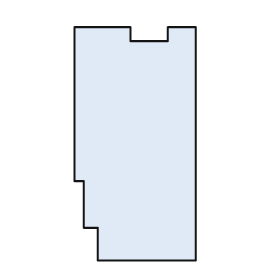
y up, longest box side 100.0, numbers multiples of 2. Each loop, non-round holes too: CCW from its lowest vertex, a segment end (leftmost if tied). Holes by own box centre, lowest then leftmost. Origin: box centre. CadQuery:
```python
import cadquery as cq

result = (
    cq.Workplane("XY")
    .moveTo(-16.0, -50.0)
    .lineTo(26.0, -50.0)
    .lineTo(26.0, 50.0)
    .lineTo(14.0, 50.0)
    .lineTo(14.0, 44.0)
    .lineTo(-2.0, 44.0)
    .lineTo(-2.0, 50.0)
    .lineTo(-26.0, 50.0)
    .lineTo(-26.0, -16.0)
    .lineTo(-22.0, -16.0)
    .lineTo(-22.0, -36.0)
    .lineTo(-16.0, -36.0)
    .close()
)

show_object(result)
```